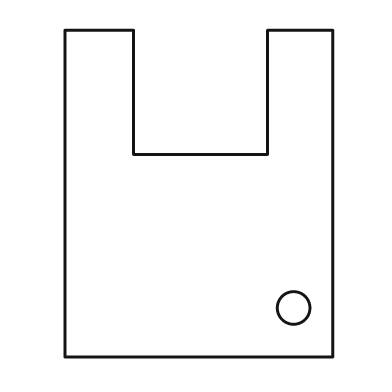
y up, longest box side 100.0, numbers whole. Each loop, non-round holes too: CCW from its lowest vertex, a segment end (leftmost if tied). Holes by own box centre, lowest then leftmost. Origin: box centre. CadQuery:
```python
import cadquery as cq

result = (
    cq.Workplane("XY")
    .moveTo(-41.0, -50.0)
    .lineTo(41.0, -50.0)
    .lineTo(41.0, 50.0)
    .lineTo(21.0, 50.0)
    .lineTo(21.0, 12.0)
    .lineTo(-20.0, 12.0)
    .lineTo(-20.0, 50.0)
    .lineTo(-41.0, 50.0)
    .close()
    .moveTo(29.0, -35.0)
    .circle(5.0)
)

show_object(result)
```